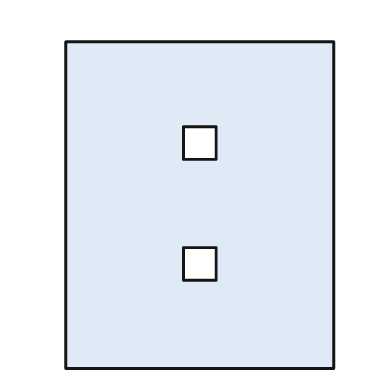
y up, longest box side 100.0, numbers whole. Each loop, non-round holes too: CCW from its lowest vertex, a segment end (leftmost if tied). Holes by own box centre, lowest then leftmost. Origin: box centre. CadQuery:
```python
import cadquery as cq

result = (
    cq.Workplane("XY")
    .moveTo(-41.0, -50.0)
    .lineTo(41.0, -50.0)
    .lineTo(41.0, 50.0)
    .lineTo(-41.0, 50.0)
    .close()
    .moveTo(-5.0, -23.0)
    .lineTo(5.0, -23.0)
    .lineTo(5.0, -13.0)
    .lineTo(-5.0, -13.0)
    .close()
    .moveTo(-5.0, 14.0)
    .lineTo(5.0, 14.0)
    .lineTo(5.0, 24.0)
    .lineTo(-5.0, 24.0)
    .close()
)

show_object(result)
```